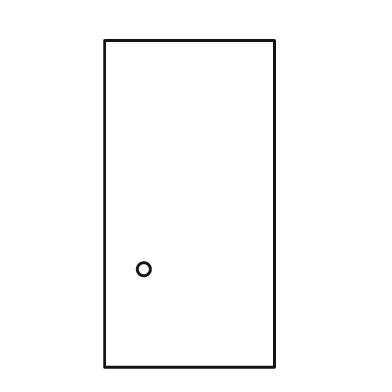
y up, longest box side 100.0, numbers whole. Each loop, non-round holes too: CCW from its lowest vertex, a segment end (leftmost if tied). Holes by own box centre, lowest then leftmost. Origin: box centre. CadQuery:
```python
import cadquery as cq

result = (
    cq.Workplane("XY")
    .moveTo(-26.0, -50.0)
    .lineTo(26.0, -50.0)
    .lineTo(26.0, 50.0)
    .lineTo(-26.0, 50.0)
    .close()
    .moveTo(-14.0, -20.0)
    .circle(2.0)
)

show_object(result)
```